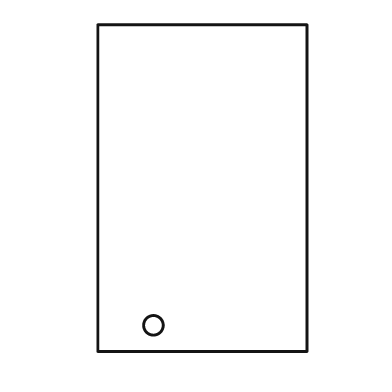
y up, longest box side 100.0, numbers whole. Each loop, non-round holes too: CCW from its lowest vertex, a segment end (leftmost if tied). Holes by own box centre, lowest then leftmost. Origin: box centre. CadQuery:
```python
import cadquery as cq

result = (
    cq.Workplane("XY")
    .moveTo(-32.0, -50.0)
    .lineTo(32.0, -50.0)
    .lineTo(32.0, 50.0)
    .lineTo(-32.0, 50.0)
    .close()
    .moveTo(-15.0, -42.0)
    .circle(3.0)
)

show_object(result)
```